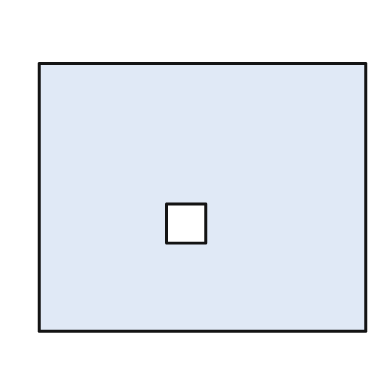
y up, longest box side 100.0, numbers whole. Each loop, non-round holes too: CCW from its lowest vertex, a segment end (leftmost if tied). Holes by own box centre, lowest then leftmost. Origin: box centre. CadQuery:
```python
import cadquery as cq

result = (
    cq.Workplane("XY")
    .moveTo(-50.0, -41.0)
    .lineTo(50.0, -41.0)
    .lineTo(50.0, 41.0)
    .lineTo(-50.0, 41.0)
    .close()
    .moveTo(-11.0, -14.0)
    .lineTo(1.0, -14.0)
    .lineTo(1.0, -2.0)
    .lineTo(-11.0, -2.0)
    .close()
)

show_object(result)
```